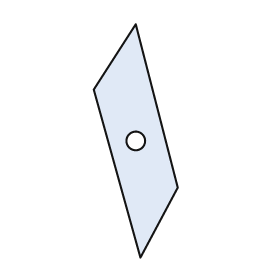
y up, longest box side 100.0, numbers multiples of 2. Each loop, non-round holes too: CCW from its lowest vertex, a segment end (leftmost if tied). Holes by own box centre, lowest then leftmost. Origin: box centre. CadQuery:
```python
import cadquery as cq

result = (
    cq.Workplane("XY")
    .moveTo(2.0, -50.0)
    .lineTo(18.0, -20.0)
    .lineTo(0.0, 50.0)
    .lineTo(-18.0, 22.0)
    .close()
    .moveTo(0.0, 0.0)
    .circle(4.0)
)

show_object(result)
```